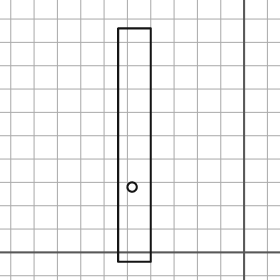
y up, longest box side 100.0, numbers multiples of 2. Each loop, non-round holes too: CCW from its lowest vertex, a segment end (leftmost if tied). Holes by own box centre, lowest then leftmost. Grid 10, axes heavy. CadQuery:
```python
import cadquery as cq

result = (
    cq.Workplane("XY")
    .moveTo(-54.0, -4.0)
    .lineTo(-40.0, -4.0)
    .lineTo(-40.0, 96.0)
    .lineTo(-54.0, 96.0)
    .close()
    .moveTo(-48.0, 28.0)
    .circle(2.0)
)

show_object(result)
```